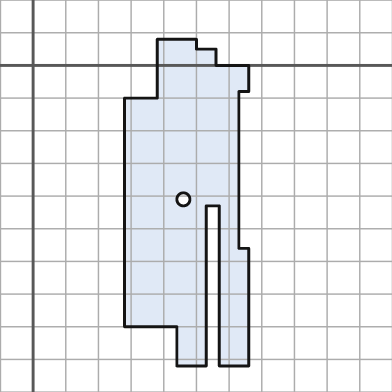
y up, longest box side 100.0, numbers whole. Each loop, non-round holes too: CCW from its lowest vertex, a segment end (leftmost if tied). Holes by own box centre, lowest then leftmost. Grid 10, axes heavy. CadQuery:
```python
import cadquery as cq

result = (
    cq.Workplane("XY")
    .moveTo(44.0, -92.0)
    .lineTo(53.0, -92.0)
    .lineTo(53.0, -43.0)
    .lineTo(57.0, -43.0)
    .lineTo(57.0, -92.0)
    .lineTo(66.0, -92.0)
    .lineTo(66.0, -56.0)
    .lineTo(63.0, -56.0)
    .lineTo(63.0, -8.0)
    .lineTo(66.0, -8.0)
    .lineTo(66.0, 0.0)
    .lineTo(56.0, 0.0)
    .lineTo(56.0, 5.0)
    .lineTo(50.0, 5.0)
    .lineTo(50.0, 8.0)
    .lineTo(38.0, 8.0)
    .lineTo(38.0, -10.0)
    .lineTo(28.0, -10.0)
    .lineTo(28.0, -80.0)
    .lineTo(44.0, -80.0)
    .close()
    .moveTo(46.0, -41.0)
    .circle(2.0)
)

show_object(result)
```